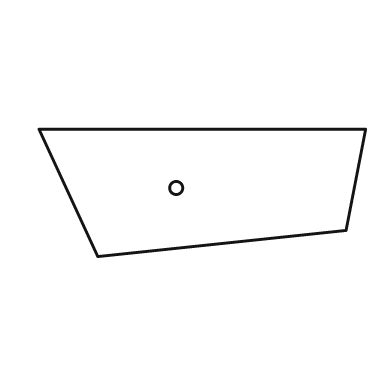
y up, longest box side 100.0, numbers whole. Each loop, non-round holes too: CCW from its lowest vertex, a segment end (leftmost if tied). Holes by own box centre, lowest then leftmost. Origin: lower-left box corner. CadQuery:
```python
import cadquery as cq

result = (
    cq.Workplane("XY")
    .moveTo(18.0, 0.0)
    .lineTo(94.0, 8.0)
    .lineTo(100.0, 39.0)
    .lineTo(0.0, 39.0)
    .close()
    .moveTo(42.0, 21.0)
    .circle(2.0)
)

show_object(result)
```